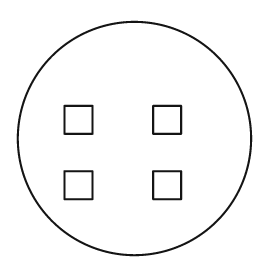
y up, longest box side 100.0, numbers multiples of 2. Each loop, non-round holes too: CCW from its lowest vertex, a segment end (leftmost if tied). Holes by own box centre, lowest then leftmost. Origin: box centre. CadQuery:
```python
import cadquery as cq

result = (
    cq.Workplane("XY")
    .moveTo(0.0, 0.0)
    .circle(50.0)
    .moveTo(-30.0, -26.0)
    .lineTo(-18.0, -26.0)
    .lineTo(-18.0, -14.0)
    .lineTo(-30.0, -14.0)
    .close()
    .moveTo(8.0, -26.0)
    .lineTo(20.0, -26.0)
    .lineTo(20.0, -14.0)
    .lineTo(8.0, -14.0)
    .close()
    .moveTo(-30.0, 2.0)
    .lineTo(-18.0, 2.0)
    .lineTo(-18.0, 14.0)
    .lineTo(-30.0, 14.0)
    .close()
    .moveTo(8.0, 2.0)
    .lineTo(20.0, 2.0)
    .lineTo(20.0, 14.0)
    .lineTo(8.0, 14.0)
    .close()
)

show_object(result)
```